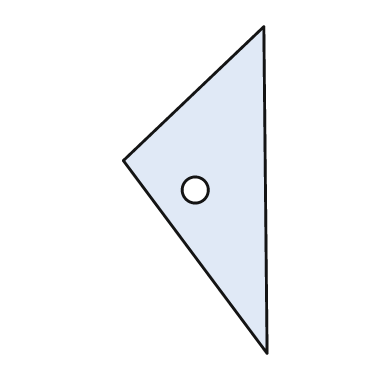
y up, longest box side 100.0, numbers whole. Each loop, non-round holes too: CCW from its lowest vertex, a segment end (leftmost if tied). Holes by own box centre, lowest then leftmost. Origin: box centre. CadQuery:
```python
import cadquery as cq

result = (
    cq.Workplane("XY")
    .moveTo(22.0, -50.0)
    .lineTo(21.0, 50.0)
    .lineTo(-22.0, 9.0)
    .close()
    .moveTo(0.0, 0.0)
    .circle(4.0)
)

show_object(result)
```